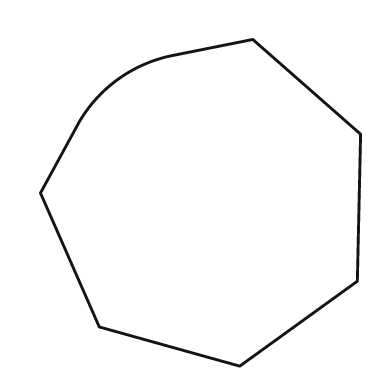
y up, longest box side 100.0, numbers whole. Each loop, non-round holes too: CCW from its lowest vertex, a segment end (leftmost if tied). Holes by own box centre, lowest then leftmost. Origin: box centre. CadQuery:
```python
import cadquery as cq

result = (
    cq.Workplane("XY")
    .moveTo(12.0, -50.0)
    .lineTo(48.0, -24.0)
    .lineTo(49.0, 21.0)
    .lineTo(16.0, 50.0)
    .lineTo(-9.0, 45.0)
    .threePointArc((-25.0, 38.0), (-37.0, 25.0))
    .lineTo(-49.0, 3.0)
    .lineTo(-31.0, -38.0)
    .close()
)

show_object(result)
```